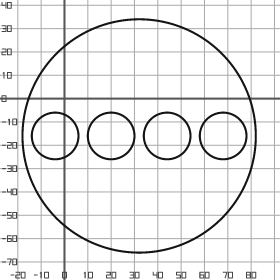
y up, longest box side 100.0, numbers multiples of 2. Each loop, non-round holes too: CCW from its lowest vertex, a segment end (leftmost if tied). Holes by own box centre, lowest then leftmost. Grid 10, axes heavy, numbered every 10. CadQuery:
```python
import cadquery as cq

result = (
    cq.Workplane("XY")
    .moveTo(32.0, -16.0)
    .circle(50.0)
    .moveTo(-4.0, -16.0)
    .circle(10.0)
    .moveTo(20.0, -16.0)
    .circle(10.0)
    .moveTo(44.0, -16.0)
    .circle(10.0)
    .moveTo(68.0, -16.0)
    .circle(10.0)
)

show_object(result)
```